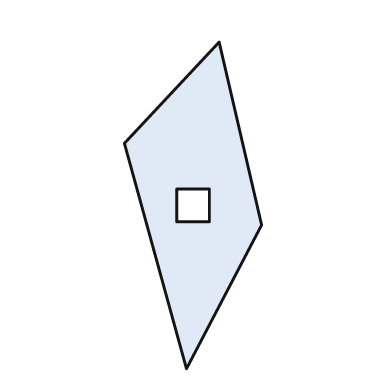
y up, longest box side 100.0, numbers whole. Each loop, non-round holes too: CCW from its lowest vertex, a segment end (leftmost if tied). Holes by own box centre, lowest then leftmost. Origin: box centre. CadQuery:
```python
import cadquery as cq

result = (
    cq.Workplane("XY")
    .moveTo(-2.0, -50.0)
    .lineTo(21.0, -6.0)
    .lineTo(8.0, 50.0)
    .lineTo(-21.0, 19.0)
    .close()
    .moveTo(-5.0, -5.0)
    .lineTo(5.0, -5.0)
    .lineTo(5.0, 5.0)
    .lineTo(-5.0, 5.0)
    .close()
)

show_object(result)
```